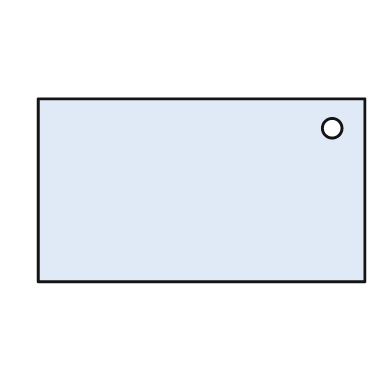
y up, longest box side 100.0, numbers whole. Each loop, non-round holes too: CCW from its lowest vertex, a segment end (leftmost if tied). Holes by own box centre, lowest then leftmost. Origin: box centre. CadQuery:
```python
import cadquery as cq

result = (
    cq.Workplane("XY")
    .moveTo(-50.0, -28.0)
    .lineTo(50.0, -28.0)
    .lineTo(50.0, 28.0)
    .lineTo(-50.0, 28.0)
    .close()
    .moveTo(40.0, 19.0)
    .circle(3.0)
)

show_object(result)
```